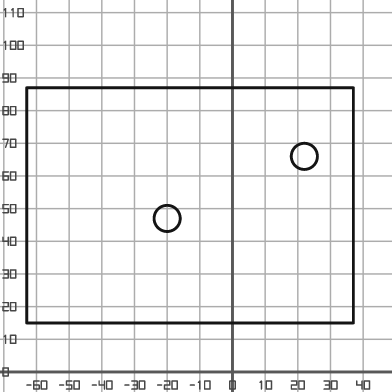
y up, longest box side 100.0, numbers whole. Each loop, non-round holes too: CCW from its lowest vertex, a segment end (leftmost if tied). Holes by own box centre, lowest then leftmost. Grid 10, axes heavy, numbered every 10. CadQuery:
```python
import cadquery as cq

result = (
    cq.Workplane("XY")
    .moveTo(-63.0, 15.0)
    .lineTo(37.0, 15.0)
    .lineTo(37.0, 87.0)
    .lineTo(-63.0, 87.0)
    .close()
    .moveTo(-20.0, 47.0)
    .circle(4.0)
    .moveTo(22.0, 66.0)
    .circle(4.0)
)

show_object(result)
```